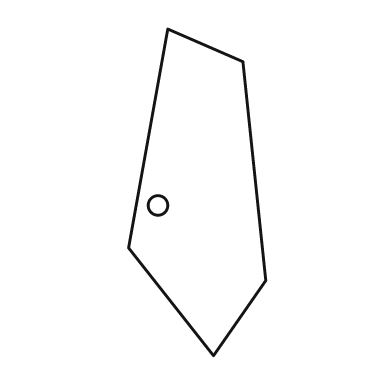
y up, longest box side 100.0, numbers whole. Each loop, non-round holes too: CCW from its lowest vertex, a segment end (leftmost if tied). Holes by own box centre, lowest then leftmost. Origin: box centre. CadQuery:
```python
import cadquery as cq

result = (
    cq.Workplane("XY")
    .moveTo(5.0, -50.0)
    .lineTo(21.0, -27.0)
    .lineTo(14.0, 40.0)
    .lineTo(-9.0, 50.0)
    .lineTo(-21.0, -17.0)
    .close()
    .moveTo(-12.0, -4.0)
    .circle(3.0)
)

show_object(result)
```